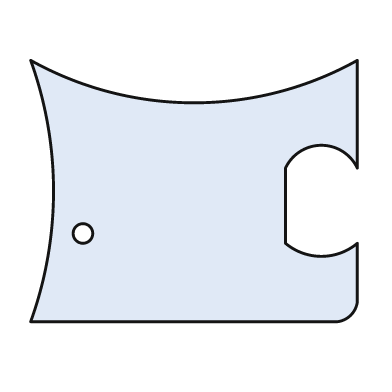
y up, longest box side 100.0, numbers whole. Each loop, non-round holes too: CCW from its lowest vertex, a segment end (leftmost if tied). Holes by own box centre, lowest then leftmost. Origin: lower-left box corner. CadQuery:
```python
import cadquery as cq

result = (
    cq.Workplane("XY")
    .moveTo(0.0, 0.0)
    .lineTo(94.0, 0.0)
    .threePointArc((98.0, 2.0), (100.0, 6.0))
    .lineTo(100.0, 24.0)
    .threePointArc((89.0, 20.0), (78.0, 24.0))
    .lineTo(78.0, 47.0)
    .threePointArc((89.0, 54.0), (100.0, 47.0))
    .lineTo(100.0, 80.0)
    .threePointArc((50.0, 67.0), (0.0, 80.0))
    .threePointArc((7.0, 40.0), (0.0, 0.0))
    .close()
    .moveTo(16.0, 27.0)
    .circle(3.0)
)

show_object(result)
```